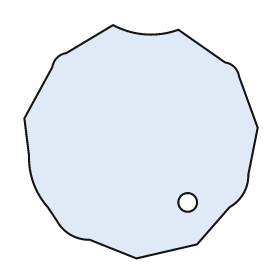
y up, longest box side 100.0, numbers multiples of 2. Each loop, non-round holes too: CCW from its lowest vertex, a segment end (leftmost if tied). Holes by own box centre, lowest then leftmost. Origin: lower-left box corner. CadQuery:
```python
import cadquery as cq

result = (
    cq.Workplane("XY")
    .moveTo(48.0, 0.0)
    .lineTo(74.0, 6.0)
    .lineTo(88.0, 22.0)
    .threePointArc((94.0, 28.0), (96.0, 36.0))
    .lineTo(100.0, 56.0)
    .lineTo(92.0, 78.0)
    .threePointArc((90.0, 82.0), (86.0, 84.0))
    .lineTo(66.0, 98.0)
    .threePointArc((52.0, 96.0), (38.0, 100.0))
    .lineTo(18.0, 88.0)
    .threePointArc((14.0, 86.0), (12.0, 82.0))
    .lineTo(0.0, 60.0)
    .lineTo(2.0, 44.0)
    .threePointArc((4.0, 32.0), (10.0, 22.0))
    .lineTo(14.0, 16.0)
    .threePointArc((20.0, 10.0), (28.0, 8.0))
    .close()
    .moveTo(70.0, 24.0)
    .circle(4.0)
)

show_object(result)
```